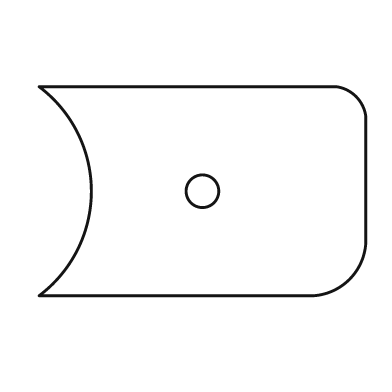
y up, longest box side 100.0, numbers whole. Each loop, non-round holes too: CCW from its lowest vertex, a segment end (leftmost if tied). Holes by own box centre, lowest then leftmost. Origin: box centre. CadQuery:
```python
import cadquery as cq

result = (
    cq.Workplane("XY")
    .moveTo(-50.0, -32.0)
    .lineTo(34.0, -32.0)
    .threePointArc((45.0, -27.0), (50.0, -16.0))
    .lineTo(50.0, 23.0)
    .threePointArc((47.0, 29.0), (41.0, 32.0))
    .lineTo(-50.0, 32.0)
    .threePointArc((-34.0, 0.0), (-50.0, -32.0))
    .close()
    .moveTo(0.0, 0.0)
    .circle(5.0)
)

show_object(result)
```